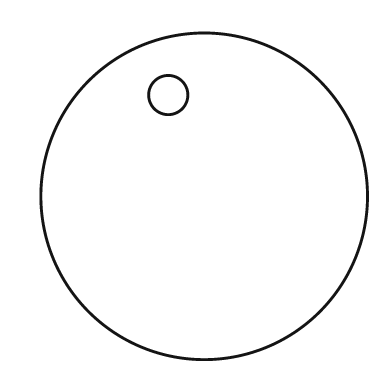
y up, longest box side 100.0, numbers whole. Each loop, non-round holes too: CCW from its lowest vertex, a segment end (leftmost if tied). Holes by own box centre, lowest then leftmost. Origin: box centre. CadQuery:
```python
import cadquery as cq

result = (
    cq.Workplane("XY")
    .moveTo(0.0, 0.0)
    .circle(50.0)
    .moveTo(-11.0, 31.0)
    .circle(6.0)
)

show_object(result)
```